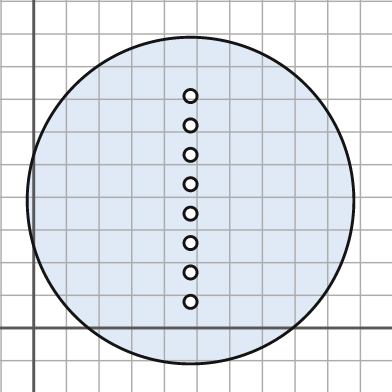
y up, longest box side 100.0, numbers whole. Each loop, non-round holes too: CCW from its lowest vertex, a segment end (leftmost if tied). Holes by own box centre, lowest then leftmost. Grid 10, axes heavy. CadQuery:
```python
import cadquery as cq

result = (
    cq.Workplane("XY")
    .moveTo(48.0, 39.0)
    .circle(50.0)
    .moveTo(48.0, 8.0)
    .circle(2.0)
    .moveTo(48.0, 17.0)
    .circle(2.0)
    .moveTo(48.0, 26.0)
    .circle(2.0)
    .moveTo(48.0, 35.0)
    .circle(2.0)
    .moveTo(48.0, 44.0)
    .circle(2.0)
    .moveTo(48.0, 53.0)
    .circle(2.0)
    .moveTo(48.0, 62.0)
    .circle(2.0)
    .moveTo(48.0, 71.0)
    .circle(2.0)
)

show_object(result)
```